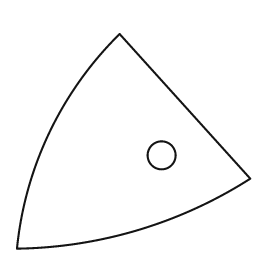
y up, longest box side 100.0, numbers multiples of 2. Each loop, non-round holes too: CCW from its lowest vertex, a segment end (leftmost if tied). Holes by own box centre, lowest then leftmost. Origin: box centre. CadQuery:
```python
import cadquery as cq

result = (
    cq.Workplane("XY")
    .moveTo(-50.0, -46.0)
    .threePointArc((2.0, -38.0), (50.0, -16.0))
    .lineTo(-6.0, 46.0)
    .threePointArc((-36.0, 4.0), (-50.0, -46.0))
    .close()
    .moveTo(12.0, -6.0)
    .circle(6.0)
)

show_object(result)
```